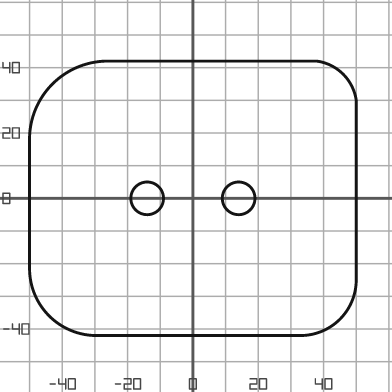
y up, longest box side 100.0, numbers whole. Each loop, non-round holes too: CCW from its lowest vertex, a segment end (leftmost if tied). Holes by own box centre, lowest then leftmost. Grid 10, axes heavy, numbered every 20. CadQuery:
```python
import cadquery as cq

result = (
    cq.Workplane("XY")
    .moveTo(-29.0, -42.0)
    .lineTo(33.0, -42.0)
    .threePointArc((45.0, -37.0), (50.0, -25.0))
    .lineTo(50.0, 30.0)
    .threePointArc((46.0, 38.0), (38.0, 42.0))
    .lineTo(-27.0, 42.0)
    .threePointArc((-43.0, 35.0), (-50.0, 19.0))
    .lineTo(-50.0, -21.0)
    .threePointArc((-44.0, -36.0), (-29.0, -42.0))
    .close()
    .moveTo(-14.0, 0.0)
    .circle(5.0)
    .moveTo(14.0, 0.0)
    .circle(5.0)
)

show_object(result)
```